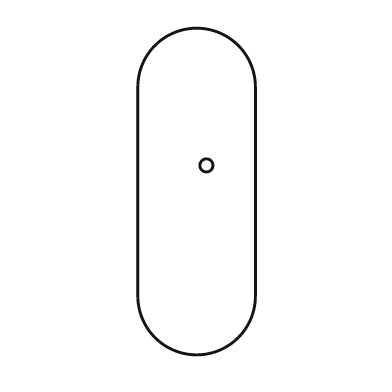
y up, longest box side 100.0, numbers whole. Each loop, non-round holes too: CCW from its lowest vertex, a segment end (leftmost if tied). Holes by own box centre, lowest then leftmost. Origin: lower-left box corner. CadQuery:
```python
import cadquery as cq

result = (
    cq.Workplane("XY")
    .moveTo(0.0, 18.0)
    .threePointArc((18.0, 0.0), (36.0, 18.0))
    .lineTo(36.0, 82.0)
    .threePointArc((18.0, 100.0), (0.0, 82.0))
    .close()
    .moveTo(21.0, 58.0)
    .circle(2.0)
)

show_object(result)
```